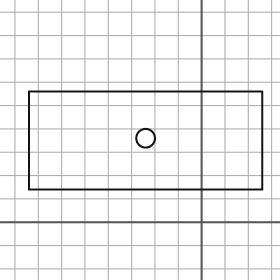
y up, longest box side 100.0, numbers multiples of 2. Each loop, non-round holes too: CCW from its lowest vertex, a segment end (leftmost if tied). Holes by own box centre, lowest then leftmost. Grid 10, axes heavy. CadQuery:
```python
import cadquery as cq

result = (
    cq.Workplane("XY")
    .moveTo(-74.0, 14.0)
    .lineTo(26.0, 14.0)
    .lineTo(26.0, 56.0)
    .lineTo(-74.0, 56.0)
    .close()
    .moveTo(-24.0, 36.0)
    .circle(4.0)
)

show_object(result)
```